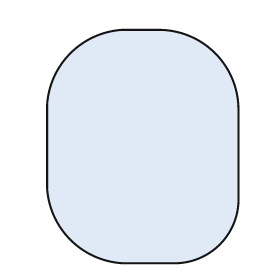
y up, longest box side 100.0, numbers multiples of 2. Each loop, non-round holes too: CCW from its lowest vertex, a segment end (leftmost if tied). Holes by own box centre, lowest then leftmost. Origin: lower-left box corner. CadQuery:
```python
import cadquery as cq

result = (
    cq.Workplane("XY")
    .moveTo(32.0, 0.0)
    .lineTo(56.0, 0.0)
    .threePointArc((74.0, 8.0), (82.0, 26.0))
    .lineTo(82.0, 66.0)
    .threePointArc((72.0, 90.0), (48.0, 100.0))
    .lineTo(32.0, 100.0)
    .threePointArc((10.0, 90.0), (0.0, 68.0))
    .lineTo(0.0, 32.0)
    .threePointArc((10.0, 10.0), (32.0, 0.0))
    .close()
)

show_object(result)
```